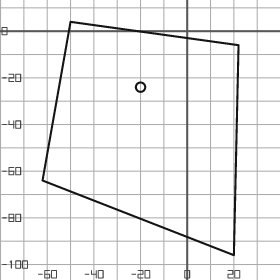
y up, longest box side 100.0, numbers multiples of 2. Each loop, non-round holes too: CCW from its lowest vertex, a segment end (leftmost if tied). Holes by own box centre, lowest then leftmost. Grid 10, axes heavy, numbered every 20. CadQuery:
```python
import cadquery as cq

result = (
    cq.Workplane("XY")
    .moveTo(20.0, -96.0)
    .lineTo(22.0, -6.0)
    .lineTo(-50.0, 4.0)
    .lineTo(-62.0, -64.0)
    .close()
    .moveTo(-20.0, -24.0)
    .circle(2.0)
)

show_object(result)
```